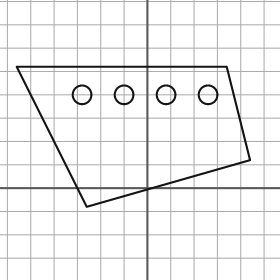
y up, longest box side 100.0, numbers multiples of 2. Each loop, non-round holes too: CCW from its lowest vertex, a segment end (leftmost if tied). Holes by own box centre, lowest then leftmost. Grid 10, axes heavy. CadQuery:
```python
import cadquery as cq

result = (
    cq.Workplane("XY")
    .moveTo(-26.0, -8.0)
    .lineTo(44.0, 12.0)
    .lineTo(34.0, 52.0)
    .lineTo(-56.0, 52.0)
    .close()
    .moveTo(-28.0, 40.0)
    .circle(4.0)
    .moveTo(-10.0, 40.0)
    .circle(4.0)
    .moveTo(8.0, 40.0)
    .circle(4.0)
    .moveTo(26.0, 40.0)
    .circle(4.0)
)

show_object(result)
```